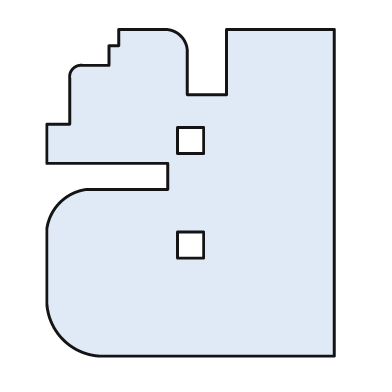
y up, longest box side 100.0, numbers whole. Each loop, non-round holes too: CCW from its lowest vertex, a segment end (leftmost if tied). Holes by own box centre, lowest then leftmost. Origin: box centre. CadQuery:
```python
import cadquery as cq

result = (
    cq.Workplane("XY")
    .moveTo(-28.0, -50.0)
    .lineTo(44.0, -50.0)
    .lineTo(44.0, 50.0)
    .lineTo(11.0, 50.0)
    .lineTo(11.0, 30.0)
    .lineTo(-1.0, 30.0)
    .lineTo(-1.0, 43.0)
    .threePointArc((-3.0, 48.0), (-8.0, 50.0))
    .lineTo(-22.0, 50.0)
    .lineTo(-22.0, 45.0)
    .lineTo(-25.0, 45.0)
    .lineTo(-25.0, 39.0)
    .lineTo(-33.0, 39.0)
    .threePointArc((-36.0, 38.0), (-37.0, 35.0))
    .lineTo(-37.0, 21.0)
    .lineTo(-44.0, 21.0)
    .lineTo(-44.0, 9.0)
    .lineTo(-7.0, 9.0)
    .lineTo(-7.0, 1.0)
    .lineTo(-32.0, 1.0)
    .threePointArc((-40.0, -3.0), (-44.0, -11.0))
    .lineTo(-44.0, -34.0)
    .threePointArc((-39.0, -45.0), (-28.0, -50.0))
    .close()
    .moveTo(-4.0, -20.0)
    .lineTo(4.0, -20.0)
    .lineTo(4.0, -12.0)
    .lineTo(-4.0, -12.0)
    .close()
    .moveTo(-4.0, 12.0)
    .lineTo(4.0, 12.0)
    .lineTo(4.0, 20.0)
    .lineTo(-4.0, 20.0)
    .close()
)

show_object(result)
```